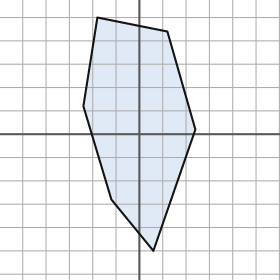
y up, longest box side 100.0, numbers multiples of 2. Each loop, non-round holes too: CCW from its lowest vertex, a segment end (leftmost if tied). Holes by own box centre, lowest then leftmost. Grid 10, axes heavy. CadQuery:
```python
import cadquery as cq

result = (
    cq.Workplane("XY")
    .moveTo(6.0, -50.0)
    .lineTo(24.0, 2.0)
    .lineTo(12.0, 44.0)
    .lineTo(-18.0, 50.0)
    .lineTo(-24.0, 12.0)
    .lineTo(-12.0, -28.0)
    .close()
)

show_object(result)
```